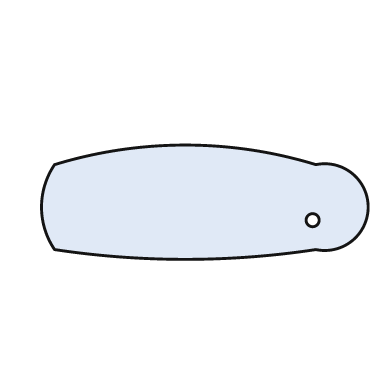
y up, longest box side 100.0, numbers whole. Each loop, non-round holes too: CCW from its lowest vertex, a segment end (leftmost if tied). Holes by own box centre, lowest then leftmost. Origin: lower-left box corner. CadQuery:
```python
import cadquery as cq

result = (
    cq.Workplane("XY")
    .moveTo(4.0, 3.0)
    .threePointArc((44.0, 0.0), (84.0, 3.0))
    .threePointArc((100.0, 16.0), (84.0, 29.0))
    .threePointArc((44.0, 35.0), (4.0, 29.0))
    .threePointArc((0.0, 16.0), (4.0, 3.0))
    .close()
    .moveTo(83.0, 12.0)
    .circle(2.0)
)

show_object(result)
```